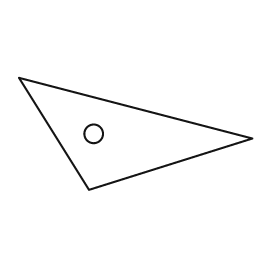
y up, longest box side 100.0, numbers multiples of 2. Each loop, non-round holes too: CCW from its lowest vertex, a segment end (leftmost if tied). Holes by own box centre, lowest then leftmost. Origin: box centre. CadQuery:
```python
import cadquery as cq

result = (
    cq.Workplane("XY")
    .moveTo(-20.0, -24.0)
    .lineTo(50.0, -2.0)
    .lineTo(-50.0, 24.0)
    .close()
    .moveTo(-18.0, 0.0)
    .circle(4.0)
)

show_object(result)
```